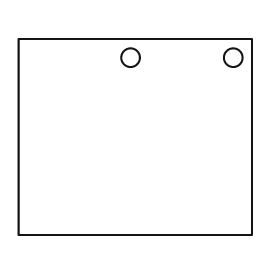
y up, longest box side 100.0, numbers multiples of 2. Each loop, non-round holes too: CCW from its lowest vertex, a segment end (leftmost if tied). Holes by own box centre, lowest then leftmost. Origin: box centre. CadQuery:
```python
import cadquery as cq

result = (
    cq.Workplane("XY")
    .moveTo(-50.0, -42.0)
    .lineTo(50.0, -42.0)
    .lineTo(50.0, 42.0)
    .lineTo(-50.0, 42.0)
    .close()
    .moveTo(-2.0, 34.0)
    .circle(4.0)
    .moveTo(42.0, 34.0)
    .circle(4.0)
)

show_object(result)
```